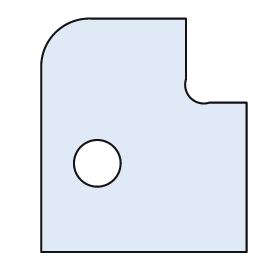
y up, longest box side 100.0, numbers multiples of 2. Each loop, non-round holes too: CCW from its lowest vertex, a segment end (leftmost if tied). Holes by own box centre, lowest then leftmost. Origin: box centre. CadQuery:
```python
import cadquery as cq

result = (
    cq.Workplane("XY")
    .moveTo(-44.0, -50.0)
    .lineTo(44.0, -50.0)
    .lineTo(44.0, 14.0)
    .lineTo(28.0, 14.0)
    .threePointArc((20.0, 16.0), (18.0, 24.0))
    .lineTo(18.0, 50.0)
    .lineTo(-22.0, 50.0)
    .threePointArc((-38.0, 44.0), (-44.0, 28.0))
    .close()
    .moveTo(-20.0, -12.0)
    .circle(10.0)
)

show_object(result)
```